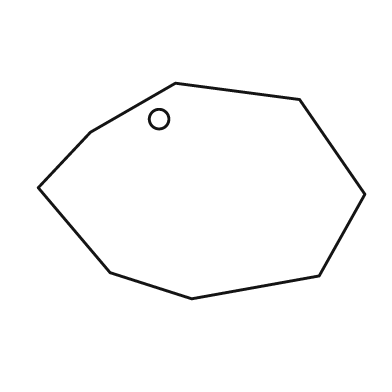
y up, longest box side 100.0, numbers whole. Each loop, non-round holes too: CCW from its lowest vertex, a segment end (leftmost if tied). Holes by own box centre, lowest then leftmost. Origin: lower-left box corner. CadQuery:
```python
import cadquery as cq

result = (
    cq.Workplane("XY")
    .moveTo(47.0, 0.0)
    .lineTo(86.0, 7.0)
    .lineTo(100.0, 32.0)
    .lineTo(80.0, 61.0)
    .lineTo(42.0, 66.0)
    .lineTo(16.0, 51.0)
    .lineTo(0.0, 34.0)
    .lineTo(22.0, 8.0)
    .close()
    .moveTo(37.0, 55.0)
    .circle(3.0)
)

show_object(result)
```